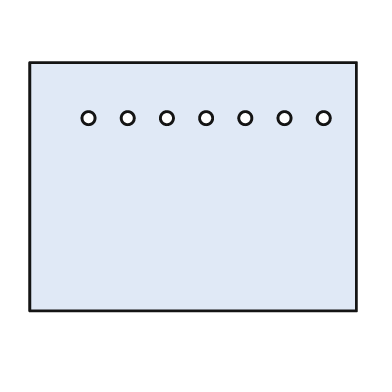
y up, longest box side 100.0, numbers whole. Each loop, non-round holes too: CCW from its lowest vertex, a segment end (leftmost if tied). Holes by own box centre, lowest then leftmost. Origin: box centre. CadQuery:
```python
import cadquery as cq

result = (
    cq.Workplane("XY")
    .moveTo(-50.0, -38.0)
    .lineTo(50.0, -38.0)
    .lineTo(50.0, 38.0)
    .lineTo(-50.0, 38.0)
    .close()
    .moveTo(-32.0, 21.0)
    .circle(2.0)
    .moveTo(-20.0, 21.0)
    .circle(2.0)
    .moveTo(-8.0, 21.0)
    .circle(2.0)
    .moveTo(4.0, 21.0)
    .circle(2.0)
    .moveTo(16.0, 21.0)
    .circle(2.0)
    .moveTo(28.0, 21.0)
    .circle(2.0)
    .moveTo(40.0, 21.0)
    .circle(2.0)
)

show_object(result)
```